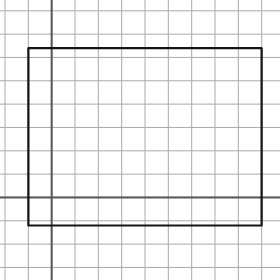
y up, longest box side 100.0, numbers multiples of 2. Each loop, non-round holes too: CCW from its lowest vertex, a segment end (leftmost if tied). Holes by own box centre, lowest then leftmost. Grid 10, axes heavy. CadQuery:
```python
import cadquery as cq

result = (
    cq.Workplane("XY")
    .moveTo(-10.0, -12.0)
    .lineTo(90.0, -12.0)
    .lineTo(90.0, 64.0)
    .lineTo(-10.0, 64.0)
    .close()
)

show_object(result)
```